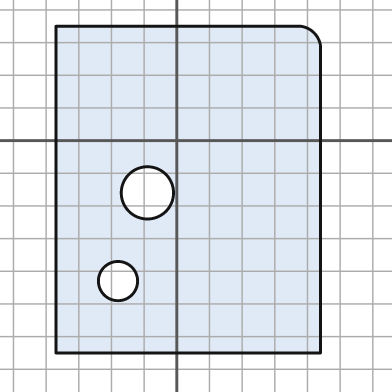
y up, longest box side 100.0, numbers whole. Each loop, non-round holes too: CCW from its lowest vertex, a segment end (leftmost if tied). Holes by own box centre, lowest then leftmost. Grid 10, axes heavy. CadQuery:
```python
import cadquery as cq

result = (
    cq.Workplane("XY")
    .moveTo(-37.0, -65.0)
    .lineTo(44.0, -65.0)
    .lineTo(44.0, 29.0)
    .threePointArc((42.0, 33.0), (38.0, 35.0))
    .lineTo(-37.0, 35.0)
    .close()
    .moveTo(-18.0, -43.0)
    .circle(6.0)
    .moveTo(-9.0, -16.0)
    .circle(8.0)
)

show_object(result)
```